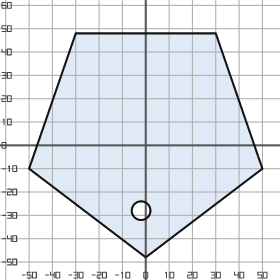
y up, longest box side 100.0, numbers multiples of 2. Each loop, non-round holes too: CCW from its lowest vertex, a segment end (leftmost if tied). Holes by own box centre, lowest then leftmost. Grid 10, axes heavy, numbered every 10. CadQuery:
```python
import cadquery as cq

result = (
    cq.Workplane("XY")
    .moveTo(0.0, -48.0)
    .lineTo(50.0, -10.0)
    .lineTo(30.0, 48.0)
    .lineTo(-30.0, 48.0)
    .lineTo(-50.0, -10.0)
    .close()
    .moveTo(-2.0, -28.0)
    .circle(4.0)
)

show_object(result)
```